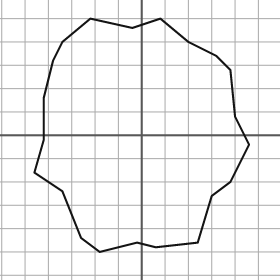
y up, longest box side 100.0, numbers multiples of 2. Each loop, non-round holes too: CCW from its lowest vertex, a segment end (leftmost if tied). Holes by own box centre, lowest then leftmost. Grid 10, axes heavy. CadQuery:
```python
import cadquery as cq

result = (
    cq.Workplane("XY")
    .moveTo(-18.0, -50.0)
    .lineTo(-2.0, -46.0)
    .lineTo(6.0, -48.0)
    .lineTo(24.0, -46.0)
    .lineTo(30.0, -26.0)
    .lineTo(38.0, -20.0)
    .lineTo(46.0, -4.0)
    .lineTo(40.0, 8.0)
    .lineTo(38.0, 28.0)
    .lineTo(32.0, 34.0)
    .lineTo(20.0, 40.0)
    .lineTo(8.0, 50.0)
    .lineTo(-4.0, 46.0)
    .lineTo(-22.0, 50.0)
    .lineTo(-34.0, 40.0)
    .lineTo(-38.0, 32.0)
    .lineTo(-42.0, 16.0)
    .lineTo(-42.0, -2.0)
    .lineTo(-46.0, -16.0)
    .lineTo(-34.0, -24.0)
    .lineTo(-26.0, -44.0)
    .close()
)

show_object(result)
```